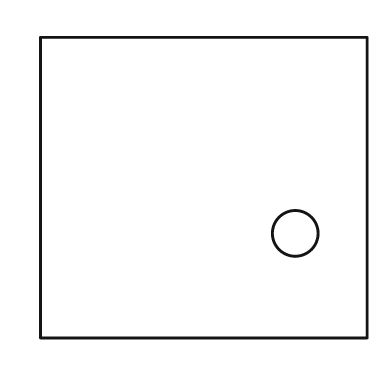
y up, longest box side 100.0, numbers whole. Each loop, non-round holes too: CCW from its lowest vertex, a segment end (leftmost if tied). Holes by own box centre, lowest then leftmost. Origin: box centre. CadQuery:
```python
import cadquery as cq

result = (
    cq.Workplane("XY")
    .moveTo(-50.0, -46.0)
    .lineTo(50.0, -46.0)
    .lineTo(50.0, 46.0)
    .lineTo(-50.0, 46.0)
    .close()
    .moveTo(28.0, -14.0)
    .circle(7.0)
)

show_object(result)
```